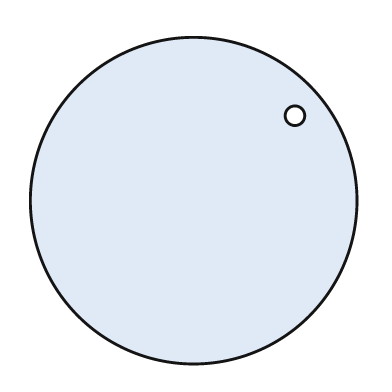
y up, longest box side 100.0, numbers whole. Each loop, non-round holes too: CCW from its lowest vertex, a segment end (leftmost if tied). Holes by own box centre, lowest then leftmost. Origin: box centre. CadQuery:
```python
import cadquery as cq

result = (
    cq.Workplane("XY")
    .moveTo(0.0, 0.0)
    .circle(50.0)
    .moveTo(31.0, 26.0)
    .circle(3.0)
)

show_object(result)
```